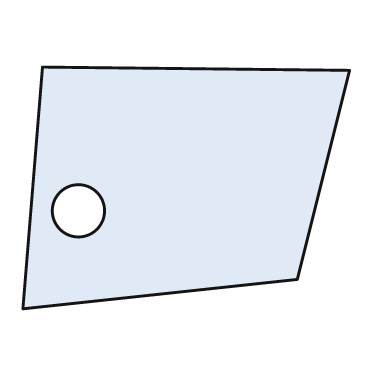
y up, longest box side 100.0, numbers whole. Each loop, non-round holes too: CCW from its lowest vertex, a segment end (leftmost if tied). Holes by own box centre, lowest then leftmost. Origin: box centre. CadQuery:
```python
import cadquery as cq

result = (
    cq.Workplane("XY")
    .moveTo(-50.0, -37.0)
    .lineTo(34.0, -28.0)
    .lineTo(50.0, 36.0)
    .lineTo(-44.0, 37.0)
    .close()
    .moveTo(-33.0, -7.0)
    .circle(8.0)
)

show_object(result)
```